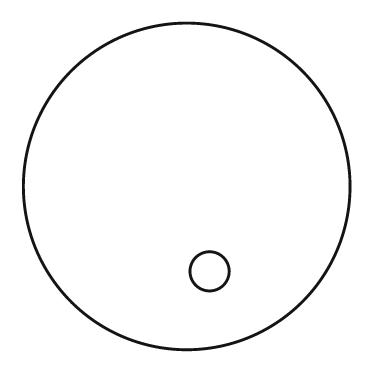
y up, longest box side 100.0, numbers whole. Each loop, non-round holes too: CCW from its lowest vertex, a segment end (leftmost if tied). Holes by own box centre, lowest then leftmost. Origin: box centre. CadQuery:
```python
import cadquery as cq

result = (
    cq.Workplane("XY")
    .moveTo(0.0, 0.0)
    .circle(50.0)
    .moveTo(7.0, -26.0)
    .circle(6.0)
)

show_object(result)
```